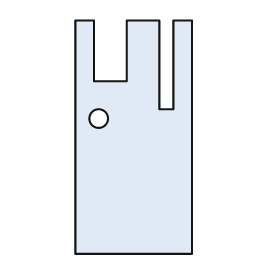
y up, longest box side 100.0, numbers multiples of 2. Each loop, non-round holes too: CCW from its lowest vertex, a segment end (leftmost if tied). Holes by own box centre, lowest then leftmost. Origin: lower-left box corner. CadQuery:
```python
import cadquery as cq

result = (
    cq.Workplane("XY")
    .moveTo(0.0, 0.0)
    .lineTo(50.0, 0.0)
    .lineTo(50.0, 100.0)
    .lineTo(42.0, 100.0)
    .lineTo(42.0, 62.0)
    .lineTo(36.0, 62.0)
    .lineTo(36.0, 100.0)
    .lineTo(22.0, 100.0)
    .lineTo(22.0, 74.0)
    .lineTo(8.0, 74.0)
    .lineTo(8.0, 100.0)
    .lineTo(0.0, 100.0)
    .close()
    .moveTo(10.0, 58.0)
    .circle(4.0)
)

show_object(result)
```